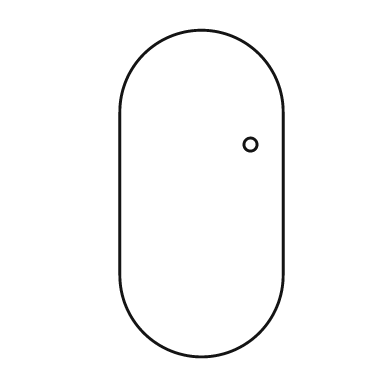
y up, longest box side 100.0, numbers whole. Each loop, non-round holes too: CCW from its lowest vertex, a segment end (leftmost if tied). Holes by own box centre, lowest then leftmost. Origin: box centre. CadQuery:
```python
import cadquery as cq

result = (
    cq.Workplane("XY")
    .moveTo(-25.0, -25.0)
    .threePointArc((0.0, -50.0), (25.0, -25.0))
    .lineTo(25.0, 25.0)
    .threePointArc((0.0, 50.0), (-25.0, 25.0))
    .close()
    .moveTo(15.0, 15.0)
    .circle(2.0)
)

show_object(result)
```